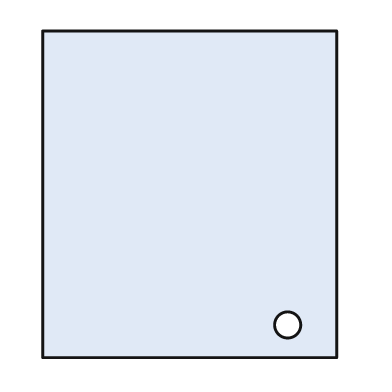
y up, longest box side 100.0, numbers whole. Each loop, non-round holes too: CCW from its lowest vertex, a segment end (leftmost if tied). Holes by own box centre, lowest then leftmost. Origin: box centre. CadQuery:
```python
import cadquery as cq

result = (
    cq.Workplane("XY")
    .moveTo(-45.0, -50.0)
    .lineTo(45.0, -50.0)
    .lineTo(45.0, 50.0)
    .lineTo(-45.0, 50.0)
    .close()
    .moveTo(30.0, -40.0)
    .circle(4.0)
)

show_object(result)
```